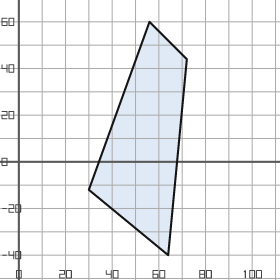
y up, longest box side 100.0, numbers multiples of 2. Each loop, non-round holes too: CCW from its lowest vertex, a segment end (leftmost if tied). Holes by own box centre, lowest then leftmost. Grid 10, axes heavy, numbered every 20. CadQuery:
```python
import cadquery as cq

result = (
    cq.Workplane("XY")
    .moveTo(64.0, -40.0)
    .lineTo(72.0, 44.0)
    .lineTo(56.0, 60.0)
    .lineTo(30.0, -12.0)
    .close()
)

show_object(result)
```